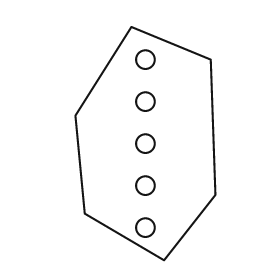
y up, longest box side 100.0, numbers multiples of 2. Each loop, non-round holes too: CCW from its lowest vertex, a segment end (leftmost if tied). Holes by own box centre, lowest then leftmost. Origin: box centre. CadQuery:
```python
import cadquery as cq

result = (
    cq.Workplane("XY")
    .moveTo(8.0, -50.0)
    .lineTo(30.0, -22.0)
    .lineTo(28.0, 36.0)
    .lineTo(-6.0, 50.0)
    .lineTo(-30.0, 12.0)
    .lineTo(-26.0, -30.0)
    .close()
    .moveTo(0.0, -36.0)
    .circle(4.0)
    .moveTo(0.0, -18.0)
    .circle(4.0)
    .moveTo(0.0, 0.0)
    .circle(4.0)
    .moveTo(0.0, 18.0)
    .circle(4.0)
    .moveTo(0.0, 36.0)
    .circle(4.0)
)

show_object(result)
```